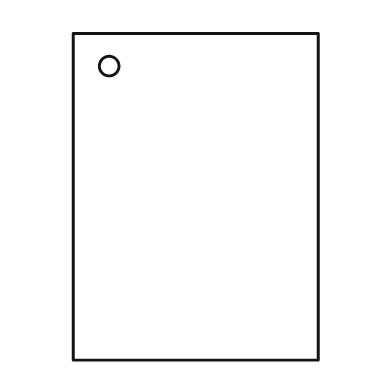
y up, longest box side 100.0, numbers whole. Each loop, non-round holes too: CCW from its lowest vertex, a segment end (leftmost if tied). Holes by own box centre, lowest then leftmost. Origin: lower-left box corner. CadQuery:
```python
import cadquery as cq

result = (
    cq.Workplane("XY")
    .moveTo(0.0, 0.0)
    .lineTo(75.0, 0.0)
    .lineTo(75.0, 100.0)
    .lineTo(0.0, 100.0)
    .close()
    .moveTo(11.0, 90.0)
    .circle(3.0)
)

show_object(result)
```